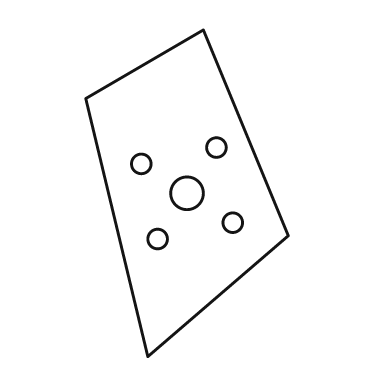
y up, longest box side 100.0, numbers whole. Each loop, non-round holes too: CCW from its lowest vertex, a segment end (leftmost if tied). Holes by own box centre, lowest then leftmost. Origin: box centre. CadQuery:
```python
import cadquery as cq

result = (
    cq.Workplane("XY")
    .moveTo(-12.0, -50.0)
    .lineTo(31.0, -13.0)
    .lineTo(5.0, 50.0)
    .lineTo(-31.0, 29.0)
    .close()
    .moveTo(-9.0, -14.0)
    .circle(3.0)
    .moveTo(14.0, -9.0)
    .circle(3.0)
    .moveTo(0.0, 0.0)
    .circle(5.0)
    .moveTo(-14.0, 9.0)
    .circle(3.0)
    .moveTo(9.0, 14.0)
    .circle(3.0)
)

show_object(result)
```